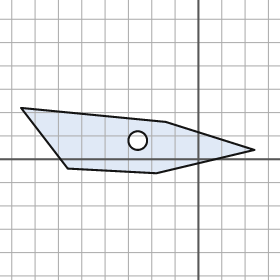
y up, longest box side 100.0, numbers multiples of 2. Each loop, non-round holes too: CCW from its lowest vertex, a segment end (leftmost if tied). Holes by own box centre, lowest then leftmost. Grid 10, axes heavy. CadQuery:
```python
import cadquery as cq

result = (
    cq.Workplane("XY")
    .moveTo(-18.0, -6.0)
    .lineTo(24.0, 4.0)
    .lineTo(-14.0, 16.0)
    .lineTo(-76.0, 22.0)
    .lineTo(-56.0, -4.0)
    .close()
    .moveTo(-26.0, 8.0)
    .circle(4.0)
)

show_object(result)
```